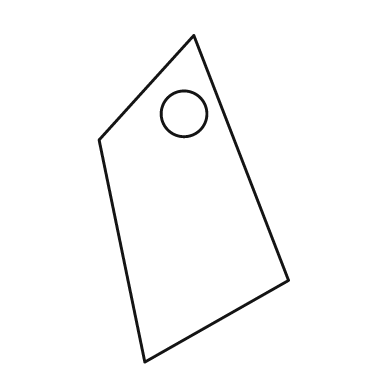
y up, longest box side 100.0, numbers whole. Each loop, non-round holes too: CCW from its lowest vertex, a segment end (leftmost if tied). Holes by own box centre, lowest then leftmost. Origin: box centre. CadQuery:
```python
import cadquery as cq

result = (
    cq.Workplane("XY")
    .moveTo(-15.0, -50.0)
    .lineTo(29.0, -25.0)
    .lineTo(0.0, 50.0)
    .lineTo(-29.0, 18.0)
    .close()
    .moveTo(-3.0, 26.0)
    .circle(7.0)
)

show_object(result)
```